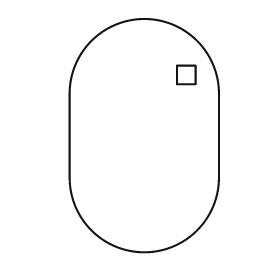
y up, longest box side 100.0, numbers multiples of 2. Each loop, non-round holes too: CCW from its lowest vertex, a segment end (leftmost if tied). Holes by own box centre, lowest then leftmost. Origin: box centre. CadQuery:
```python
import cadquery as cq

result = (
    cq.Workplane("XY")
    .moveTo(-32.0, -18.0)
    .threePointArc((0.0, -50.0), (32.0, -18.0))
    .lineTo(32.0, 18.0)
    .threePointArc((0.0, 50.0), (-32.0, 18.0))
    .close()
    .moveTo(14.0, 22.0)
    .lineTo(22.0, 22.0)
    .lineTo(22.0, 30.0)
    .lineTo(14.0, 30.0)
    .close()
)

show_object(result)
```